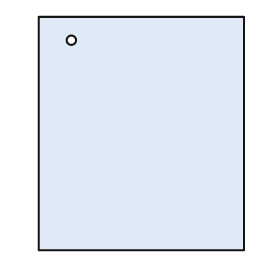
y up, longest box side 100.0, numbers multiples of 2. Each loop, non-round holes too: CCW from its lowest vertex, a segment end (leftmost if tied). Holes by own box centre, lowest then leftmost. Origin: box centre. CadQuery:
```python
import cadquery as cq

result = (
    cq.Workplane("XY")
    .moveTo(-44.0, -50.0)
    .lineTo(44.0, -50.0)
    .lineTo(44.0, 50.0)
    .lineTo(-44.0, 50.0)
    .close()
    .moveTo(-30.0, 40.0)
    .circle(2.0)
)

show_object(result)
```